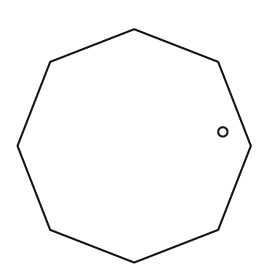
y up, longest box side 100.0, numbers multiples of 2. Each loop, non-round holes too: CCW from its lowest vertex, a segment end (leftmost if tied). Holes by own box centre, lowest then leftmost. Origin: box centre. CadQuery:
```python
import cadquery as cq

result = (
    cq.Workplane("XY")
    .moveTo(0.0, -50.0)
    .lineTo(36.0, -36.0)
    .lineTo(50.0, 0.0)
    .lineTo(36.0, 36.0)
    .lineTo(0.0, 50.0)
    .lineTo(-36.0, 36.0)
    .lineTo(-50.0, 0.0)
    .lineTo(-36.0, -36.0)
    .close()
    .moveTo(38.0, 6.0)
    .circle(2.0)
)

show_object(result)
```